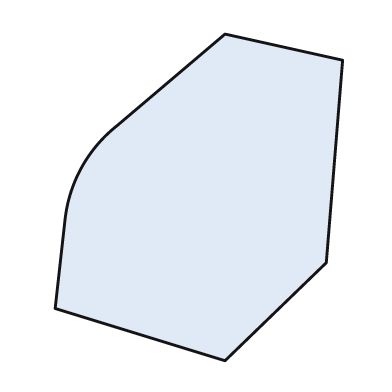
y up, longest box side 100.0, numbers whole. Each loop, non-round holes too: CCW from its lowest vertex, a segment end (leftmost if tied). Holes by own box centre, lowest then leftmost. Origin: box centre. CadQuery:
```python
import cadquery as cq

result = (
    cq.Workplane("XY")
    .moveTo(8.0, -50.0)
    .lineTo(39.0, -20.0)
    .lineTo(44.0, 42.0)
    .lineTo(8.0, 50.0)
    .lineTo(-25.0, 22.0)
    .threePointArc((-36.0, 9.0), (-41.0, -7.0))
    .lineTo(-44.0, -34.0)
    .close()
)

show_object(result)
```